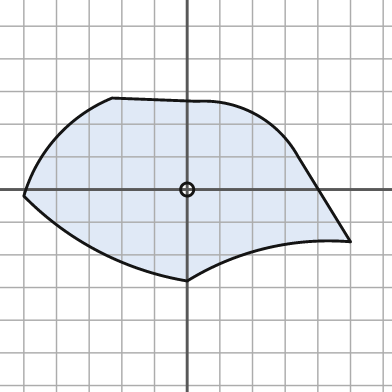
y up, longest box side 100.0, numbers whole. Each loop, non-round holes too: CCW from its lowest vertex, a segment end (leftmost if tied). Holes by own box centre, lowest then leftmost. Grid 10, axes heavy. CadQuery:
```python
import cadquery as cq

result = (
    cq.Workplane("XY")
    .moveTo(0.0, -28.0)
    .threePointArc((24.0, -18.0), (50.0, -16.0))
    .lineTo(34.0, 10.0)
    .threePointArc((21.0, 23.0), (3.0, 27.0))
    .lineTo(-23.0, 28.0)
    .threePointArc((-40.0, 16.0), (-50.0, -2.0))
    .threePointArc((-27.0, -19.0), (0.0, -28.0))
    .close()
    .moveTo(0.0, 0.0)
    .circle(2.0)
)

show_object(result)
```